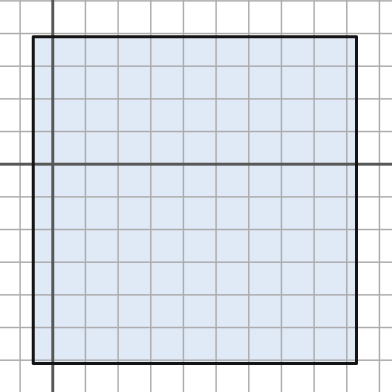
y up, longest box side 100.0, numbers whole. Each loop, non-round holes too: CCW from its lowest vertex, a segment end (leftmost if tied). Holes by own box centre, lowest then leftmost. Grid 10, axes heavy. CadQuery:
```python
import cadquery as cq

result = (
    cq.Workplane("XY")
    .moveTo(-6.0, -61.0)
    .lineTo(93.0, -61.0)
    .lineTo(93.0, 39.0)
    .lineTo(-6.0, 39.0)
    .close()
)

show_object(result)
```